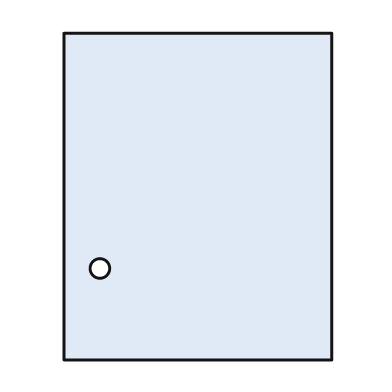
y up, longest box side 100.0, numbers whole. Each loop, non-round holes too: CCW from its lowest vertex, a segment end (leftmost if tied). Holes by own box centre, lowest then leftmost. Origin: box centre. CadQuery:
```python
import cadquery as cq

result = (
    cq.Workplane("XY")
    .moveTo(-41.0, -50.0)
    .lineTo(41.0, -50.0)
    .lineTo(41.0, 50.0)
    .lineTo(-41.0, 50.0)
    .close()
    .moveTo(-30.0, -22.0)
    .circle(3.0)
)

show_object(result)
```